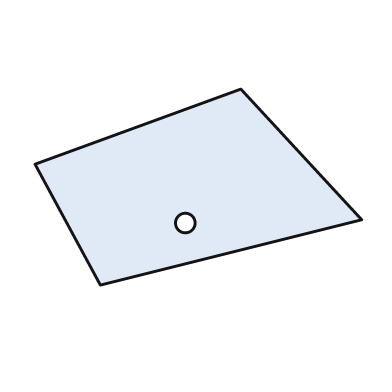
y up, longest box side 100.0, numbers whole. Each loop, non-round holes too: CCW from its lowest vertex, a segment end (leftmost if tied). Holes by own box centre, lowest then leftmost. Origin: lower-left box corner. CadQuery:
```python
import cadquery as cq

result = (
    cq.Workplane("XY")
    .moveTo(20.0, 0.0)
    .lineTo(100.0, 20.0)
    .lineTo(63.0, 60.0)
    .lineTo(0.0, 37.0)
    .close()
    .moveTo(46.0, 19.0)
    .circle(3.0)
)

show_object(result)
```